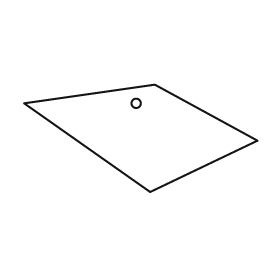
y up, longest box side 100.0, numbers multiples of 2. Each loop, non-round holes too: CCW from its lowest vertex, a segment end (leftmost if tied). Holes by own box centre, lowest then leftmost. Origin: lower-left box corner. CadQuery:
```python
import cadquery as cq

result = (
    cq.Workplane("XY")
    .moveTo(54.0, 0.0)
    .lineTo(100.0, 22.0)
    .lineTo(56.0, 46.0)
    .lineTo(0.0, 38.0)
    .close()
    .moveTo(48.0, 38.0)
    .circle(2.0)
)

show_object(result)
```